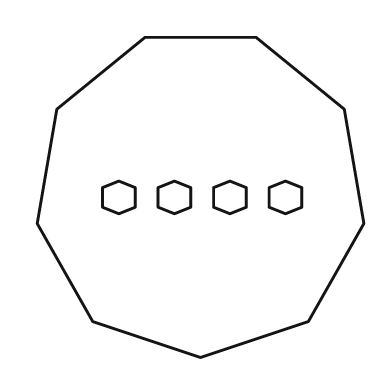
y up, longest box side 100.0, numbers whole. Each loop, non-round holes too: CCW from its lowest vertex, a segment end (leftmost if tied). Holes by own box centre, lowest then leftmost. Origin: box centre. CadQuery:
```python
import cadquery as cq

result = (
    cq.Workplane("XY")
    .moveTo(0.0, -49.0)
    .lineTo(33.0, -38.0)
    .lineTo(50.0, -8.0)
    .lineTo(44.0, 27.0)
    .lineTo(17.0, 49.0)
    .lineTo(-17.0, 49.0)
    .lineTo(-44.0, 27.0)
    .lineTo(-50.0, -8.0)
    .lineTo(-33.0, -38.0)
    .close()
    .moveTo(-25.0, -5.0)
    .lineTo(-20.0, -3.0)
    .lineTo(-20.0, 3.0)
    .lineTo(-25.0, 5.0)
    .lineTo(-30.0, 3.0)
    .lineTo(-30.0, -3.0)
    .close()
    .moveTo(-8.0, -5.0)
    .lineTo(-3.0, -3.0)
    .lineTo(-3.0, 3.0)
    .lineTo(-8.0, 5.0)
    .lineTo(-13.0, 3.0)
    .lineTo(-13.0, -3.0)
    .close()
    .moveTo(9.0, -5.0)
    .lineTo(14.0, -3.0)
    .lineTo(14.0, 3.0)
    .lineTo(9.0, 5.0)
    .lineTo(4.0, 3.0)
    .lineTo(4.0, -3.0)
    .close()
    .moveTo(26.0, -5.0)
    .lineTo(31.0, -3.0)
    .lineTo(31.0, 3.0)
    .lineTo(26.0, 5.0)
    .lineTo(21.0, 3.0)
    .lineTo(21.0, -3.0)
    .close()
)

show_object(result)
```